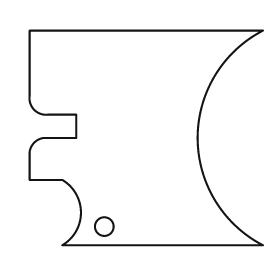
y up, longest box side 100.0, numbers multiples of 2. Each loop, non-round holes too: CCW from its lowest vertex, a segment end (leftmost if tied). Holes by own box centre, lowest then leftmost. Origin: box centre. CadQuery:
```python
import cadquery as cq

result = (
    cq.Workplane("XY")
    .moveTo(-36.0, -46.0)
    .lineTo(50.0, -46.0)
    .threePointArc((22.0, 0.0), (50.0, 46.0))
    .lineTo(-50.0, 46.0)
    .lineTo(-50.0, 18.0)
    .threePointArc((-48.0, 12.0), (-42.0, 10.0))
    .lineTo(-30.0, 10.0)
    .lineTo(-30.0, 0.0)
    .lineTo(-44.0, 0.0)
    .threePointArc((-48.0, -2.0), (-50.0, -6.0))
    .lineTo(-50.0, -18.0)
    .lineTo(-36.0, -18.0)
    .threePointArc((-28.0, -32.0), (-36.0, -46.0))
    .close()
    .moveTo(-18.0, -38.0)
    .circle(4.0)
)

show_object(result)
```